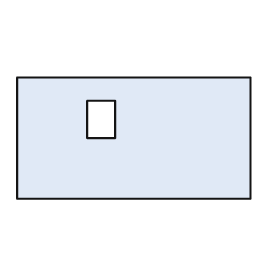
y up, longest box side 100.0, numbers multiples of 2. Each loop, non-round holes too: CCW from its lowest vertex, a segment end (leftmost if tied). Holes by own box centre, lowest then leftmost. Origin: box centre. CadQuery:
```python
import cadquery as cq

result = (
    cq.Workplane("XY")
    .moveTo(-50.0, -26.0)
    .lineTo(50.0, -26.0)
    .lineTo(50.0, 26.0)
    .lineTo(-50.0, 26.0)
    .close()
    .moveTo(-20.0, 0.0)
    .lineTo(-8.0, 0.0)
    .lineTo(-8.0, 16.0)
    .lineTo(-20.0, 16.0)
    .close()
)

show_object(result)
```